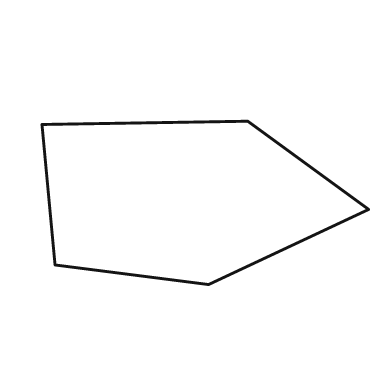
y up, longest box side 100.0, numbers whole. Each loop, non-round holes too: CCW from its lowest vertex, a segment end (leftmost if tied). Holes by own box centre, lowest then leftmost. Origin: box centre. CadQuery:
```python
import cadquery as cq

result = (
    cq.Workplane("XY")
    .moveTo(1.0, -25.0)
    .lineTo(50.0, -2.0)
    .lineTo(13.0, 25.0)
    .lineTo(-50.0, 24.0)
    .lineTo(-46.0, -19.0)
    .close()
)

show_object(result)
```